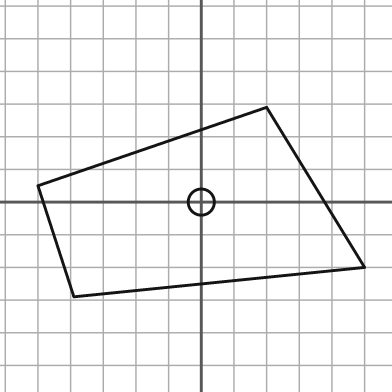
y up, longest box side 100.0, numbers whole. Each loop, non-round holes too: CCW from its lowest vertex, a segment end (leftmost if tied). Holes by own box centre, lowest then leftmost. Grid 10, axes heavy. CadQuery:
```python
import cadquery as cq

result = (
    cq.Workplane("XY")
    .moveTo(-39.0, -29.0)
    .lineTo(50.0, -20.0)
    .lineTo(20.0, 29.0)
    .lineTo(-50.0, 5.0)
    .close()
    .moveTo(0.0, 0.0)
    .circle(4.0)
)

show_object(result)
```